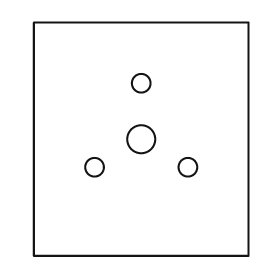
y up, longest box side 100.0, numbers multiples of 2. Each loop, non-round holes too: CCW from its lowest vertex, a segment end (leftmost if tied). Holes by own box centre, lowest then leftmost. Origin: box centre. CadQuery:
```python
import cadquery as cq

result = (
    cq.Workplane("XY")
    .moveTo(-46.0, -50.0)
    .lineTo(46.0, -50.0)
    .lineTo(46.0, 50.0)
    .lineTo(-46.0, 50.0)
    .close()
    .moveTo(-20.0, -12.0)
    .circle(4.0)
    .moveTo(20.0, -12.0)
    .circle(4.0)
    .moveTo(0.0, 0.0)
    .circle(6.0)
    .moveTo(0.0, 24.0)
    .circle(4.0)
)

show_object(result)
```